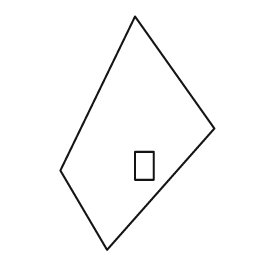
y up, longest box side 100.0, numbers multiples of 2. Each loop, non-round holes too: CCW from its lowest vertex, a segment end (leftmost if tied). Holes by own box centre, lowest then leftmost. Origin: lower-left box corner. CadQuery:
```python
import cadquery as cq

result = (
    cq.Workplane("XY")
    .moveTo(20.0, 0.0)
    .lineTo(66.0, 52.0)
    .lineTo(32.0, 100.0)
    .lineTo(0.0, 34.0)
    .close()
    .moveTo(32.0, 30.0)
    .lineTo(40.0, 30.0)
    .lineTo(40.0, 42.0)
    .lineTo(32.0, 42.0)
    .close()
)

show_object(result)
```